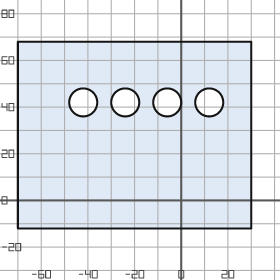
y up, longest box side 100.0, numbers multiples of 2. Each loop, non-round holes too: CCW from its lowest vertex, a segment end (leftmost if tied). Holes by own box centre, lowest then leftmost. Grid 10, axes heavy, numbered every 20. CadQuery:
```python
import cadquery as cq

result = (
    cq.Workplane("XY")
    .moveTo(-70.0, -12.0)
    .lineTo(30.0, -12.0)
    .lineTo(30.0, 68.0)
    .lineTo(-70.0, 68.0)
    .close()
    .moveTo(-42.0, 42.0)
    .circle(6.0)
    .moveTo(-24.0, 42.0)
    .circle(6.0)
    .moveTo(-6.0, 42.0)
    .circle(6.0)
    .moveTo(12.0, 42.0)
    .circle(6.0)
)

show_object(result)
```